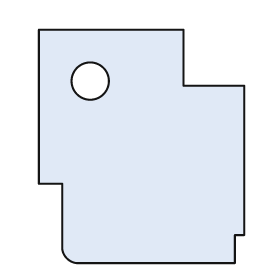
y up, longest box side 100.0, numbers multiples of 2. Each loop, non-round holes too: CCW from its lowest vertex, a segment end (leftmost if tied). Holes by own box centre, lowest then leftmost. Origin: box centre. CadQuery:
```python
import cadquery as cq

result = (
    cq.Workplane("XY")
    .moveTo(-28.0, -50.0)
    .lineTo(40.0, -50.0)
    .lineTo(40.0, -38.0)
    .lineTo(44.0, -38.0)
    .lineTo(44.0, 26.0)
    .lineTo(18.0, 26.0)
    .lineTo(18.0, 50.0)
    .lineTo(-44.0, 50.0)
    .lineTo(-44.0, -16.0)
    .lineTo(-34.0, -16.0)
    .lineTo(-34.0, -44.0)
    .threePointArc((-32.0, -48.0), (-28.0, -50.0))
    .close()
    .moveTo(-22.0, 28.0)
    .circle(8.0)
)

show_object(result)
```